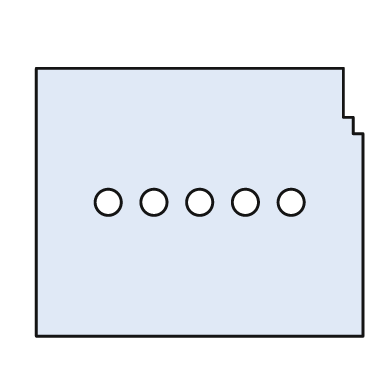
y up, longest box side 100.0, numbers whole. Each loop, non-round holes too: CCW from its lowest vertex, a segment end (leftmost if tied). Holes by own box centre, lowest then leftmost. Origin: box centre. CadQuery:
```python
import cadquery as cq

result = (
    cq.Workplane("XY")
    .moveTo(-50.0, -41.0)
    .lineTo(50.0, -41.0)
    .lineTo(50.0, 21.0)
    .lineTo(47.0, 21.0)
    .lineTo(47.0, 26.0)
    .lineTo(44.0, 26.0)
    .lineTo(44.0, 41.0)
    .lineTo(-50.0, 41.0)
    .close()
    .moveTo(-28.0, 0.0)
    .circle(4.0)
    .moveTo(-14.0, 0.0)
    .circle(4.0)
    .moveTo(0.0, 0.0)
    .circle(4.0)
    .moveTo(14.0, 0.0)
    .circle(4.0)
    .moveTo(28.0, 0.0)
    .circle(4.0)
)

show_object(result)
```